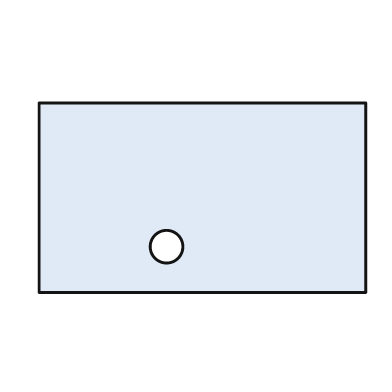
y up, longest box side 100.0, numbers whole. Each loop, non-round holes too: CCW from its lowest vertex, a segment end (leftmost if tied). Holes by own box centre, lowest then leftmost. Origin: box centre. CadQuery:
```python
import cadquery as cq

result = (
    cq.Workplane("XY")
    .moveTo(-50.0, -29.0)
    .lineTo(50.0, -29.0)
    .lineTo(50.0, 29.0)
    .lineTo(-50.0, 29.0)
    .close()
    .moveTo(-11.0, -15.0)
    .circle(5.0)
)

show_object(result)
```